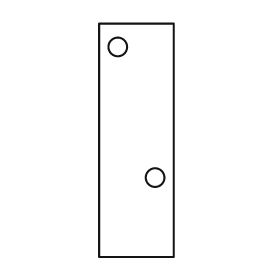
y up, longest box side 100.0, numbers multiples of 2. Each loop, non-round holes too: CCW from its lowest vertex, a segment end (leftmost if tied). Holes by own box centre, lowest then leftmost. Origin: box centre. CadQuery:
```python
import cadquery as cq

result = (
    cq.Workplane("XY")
    .moveTo(-16.0, -50.0)
    .lineTo(16.0, -50.0)
    .lineTo(16.0, 50.0)
    .lineTo(-16.0, 50.0)
    .close()
    .moveTo(8.0, -16.0)
    .circle(4.0)
    .moveTo(-8.0, 40.0)
    .circle(4.0)
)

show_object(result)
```